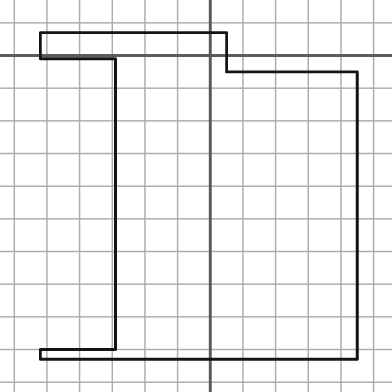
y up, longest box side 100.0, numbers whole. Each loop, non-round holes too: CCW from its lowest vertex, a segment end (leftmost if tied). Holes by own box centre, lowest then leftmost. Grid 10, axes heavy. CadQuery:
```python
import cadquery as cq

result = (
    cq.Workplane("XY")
    .moveTo(-52.0, -93.0)
    .lineTo(45.0, -93.0)
    .lineTo(45.0, -5.0)
    .lineTo(5.0, -5.0)
    .lineTo(5.0, 7.0)
    .lineTo(-52.0, 7.0)
    .lineTo(-52.0, -1.0)
    .lineTo(-29.0, -1.0)
    .lineTo(-29.0, -90.0)
    .lineTo(-52.0, -90.0)
    .close()
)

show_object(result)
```